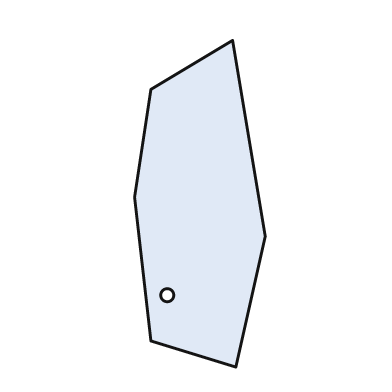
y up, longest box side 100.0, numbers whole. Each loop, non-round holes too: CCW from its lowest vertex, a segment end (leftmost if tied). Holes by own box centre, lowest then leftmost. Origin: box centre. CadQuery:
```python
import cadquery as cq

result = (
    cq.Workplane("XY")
    .moveTo(11.0, -50.0)
    .lineTo(20.0, -10.0)
    .lineTo(10.0, 50.0)
    .lineTo(-15.0, 35.0)
    .lineTo(-20.0, 2.0)
    .lineTo(-15.0, -42.0)
    .close()
    .moveTo(-10.0, -28.0)
    .circle(2.0)
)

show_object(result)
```